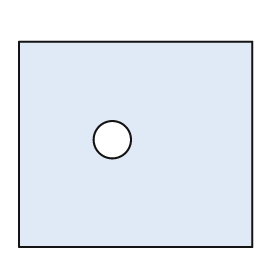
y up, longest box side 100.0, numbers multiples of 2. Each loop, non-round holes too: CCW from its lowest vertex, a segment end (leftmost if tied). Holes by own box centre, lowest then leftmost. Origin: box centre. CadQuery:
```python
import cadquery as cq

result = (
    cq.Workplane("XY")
    .moveTo(-50.0, -44.0)
    .lineTo(50.0, -44.0)
    .lineTo(50.0, 44.0)
    .lineTo(-50.0, 44.0)
    .close()
    .moveTo(-10.0, 2.0)
    .circle(8.0)
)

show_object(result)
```